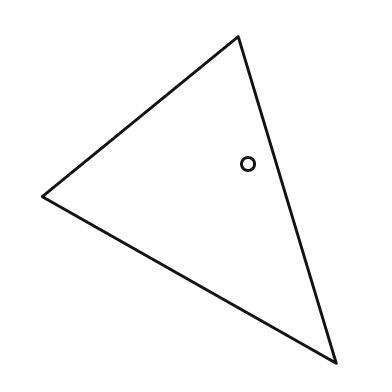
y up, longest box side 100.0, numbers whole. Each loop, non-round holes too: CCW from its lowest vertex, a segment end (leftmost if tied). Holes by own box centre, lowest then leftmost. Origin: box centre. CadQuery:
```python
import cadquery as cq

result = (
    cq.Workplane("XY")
    .moveTo(45.0, -50.0)
    .lineTo(15.0, 50.0)
    .lineTo(-45.0, 1.0)
    .close()
    .moveTo(18.0, 11.0)
    .circle(2.0)
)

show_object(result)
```